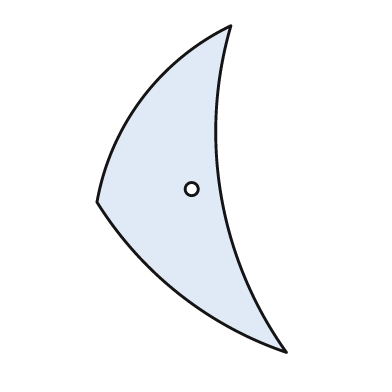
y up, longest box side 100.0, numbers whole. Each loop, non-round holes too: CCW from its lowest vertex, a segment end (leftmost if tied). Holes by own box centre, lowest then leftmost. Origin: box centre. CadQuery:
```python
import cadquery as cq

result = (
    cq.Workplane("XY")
    .moveTo(29.0, -50.0)
    .threePointArc((9.0, -2.0), (12.0, 50.0))
    .threePointArc((-15.0, 28.0), (-29.0, -4.0))
    .threePointArc((-4.0, -32.0), (29.0, -50.0))
    .close()
    .moveTo(0.0, 0.0)
    .circle(2.0)
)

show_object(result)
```